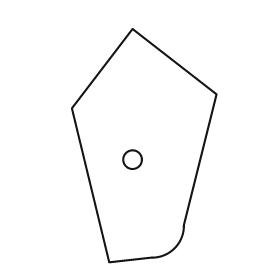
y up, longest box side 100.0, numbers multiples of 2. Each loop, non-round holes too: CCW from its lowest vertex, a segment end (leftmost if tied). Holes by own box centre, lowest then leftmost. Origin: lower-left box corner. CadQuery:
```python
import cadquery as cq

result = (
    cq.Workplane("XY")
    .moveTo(16.0, 0.0)
    .lineTo(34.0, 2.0)
    .threePointArc((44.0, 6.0), (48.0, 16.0))
    .lineTo(62.0, 72.0)
    .lineTo(26.0, 100.0)
    .lineTo(0.0, 66.0)
    .close()
    .moveTo(26.0, 44.0)
    .circle(4.0)
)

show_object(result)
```